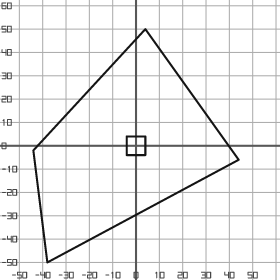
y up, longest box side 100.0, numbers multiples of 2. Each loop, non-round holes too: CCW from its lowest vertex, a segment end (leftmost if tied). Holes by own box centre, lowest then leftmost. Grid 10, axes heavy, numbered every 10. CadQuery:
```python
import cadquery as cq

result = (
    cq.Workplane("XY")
    .moveTo(-38.0, -50.0)
    .lineTo(44.0, -6.0)
    .lineTo(4.0, 50.0)
    .lineTo(-44.0, -2.0)
    .close()
    .moveTo(-4.0, -4.0)
    .lineTo(4.0, -4.0)
    .lineTo(4.0, 4.0)
    .lineTo(-4.0, 4.0)
    .close()
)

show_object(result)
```